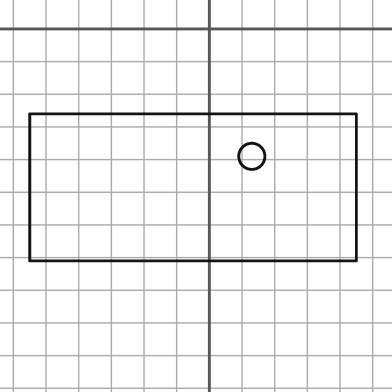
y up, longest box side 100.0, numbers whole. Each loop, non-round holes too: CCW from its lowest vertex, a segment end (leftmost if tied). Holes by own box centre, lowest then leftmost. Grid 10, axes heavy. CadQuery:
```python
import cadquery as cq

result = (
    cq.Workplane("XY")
    .moveTo(-55.0, -71.0)
    .lineTo(45.0, -71.0)
    .lineTo(45.0, -26.0)
    .lineTo(-55.0, -26.0)
    .close()
    .moveTo(13.0, -39.0)
    .circle(4.0)
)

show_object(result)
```